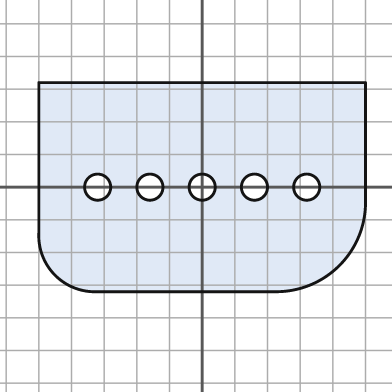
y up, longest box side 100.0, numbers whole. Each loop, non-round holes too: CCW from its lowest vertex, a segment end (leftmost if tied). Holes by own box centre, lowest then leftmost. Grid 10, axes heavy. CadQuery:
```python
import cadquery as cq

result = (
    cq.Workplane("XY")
    .moveTo(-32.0, -32.0)
    .lineTo(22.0, -32.0)
    .threePointArc((42.0, -24.0), (50.0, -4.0))
    .lineTo(50.0, 32.0)
    .lineTo(-50.0, 32.0)
    .lineTo(-50.0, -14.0)
    .threePointArc((-45.0, -27.0), (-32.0, -32.0))
    .close()
    .moveTo(-32.0, 0.0)
    .circle(4.0)
    .moveTo(-16.0, 0.0)
    .circle(4.0)
    .moveTo(0.0, 0.0)
    .circle(4.0)
    .moveTo(16.0, 0.0)
    .circle(4.0)
    .moveTo(32.0, 0.0)
    .circle(4.0)
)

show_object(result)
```